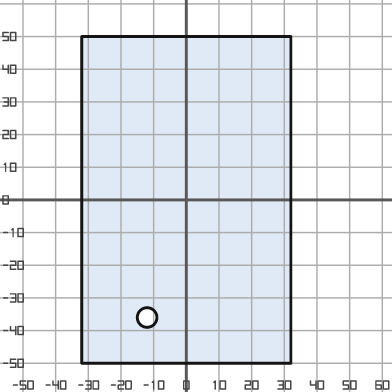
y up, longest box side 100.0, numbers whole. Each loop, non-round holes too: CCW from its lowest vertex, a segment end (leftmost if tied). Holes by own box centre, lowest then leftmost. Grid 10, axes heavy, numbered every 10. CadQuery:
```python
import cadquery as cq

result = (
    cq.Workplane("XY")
    .moveTo(-32.0, -50.0)
    .lineTo(32.0, -50.0)
    .lineTo(32.0, 50.0)
    .lineTo(-32.0, 50.0)
    .close()
    .moveTo(-12.0, -36.0)
    .circle(3.0)
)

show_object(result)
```